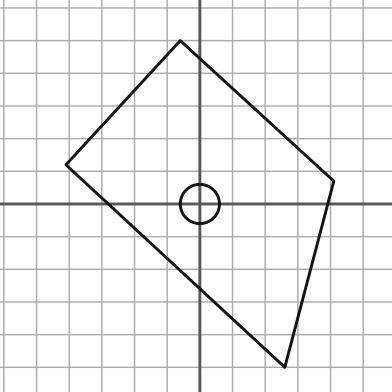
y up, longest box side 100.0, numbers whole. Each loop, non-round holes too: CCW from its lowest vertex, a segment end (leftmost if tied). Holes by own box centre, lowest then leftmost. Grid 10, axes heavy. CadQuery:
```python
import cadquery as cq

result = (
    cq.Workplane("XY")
    .moveTo(26.0, -50.0)
    .lineTo(41.0, 7.0)
    .lineTo(-6.0, 50.0)
    .lineTo(-41.0, 12.0)
    .close()
    .moveTo(0.0, 0.0)
    .circle(6.0)
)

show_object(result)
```